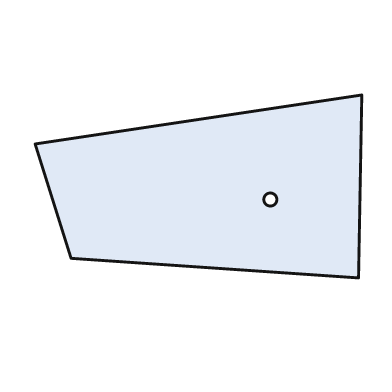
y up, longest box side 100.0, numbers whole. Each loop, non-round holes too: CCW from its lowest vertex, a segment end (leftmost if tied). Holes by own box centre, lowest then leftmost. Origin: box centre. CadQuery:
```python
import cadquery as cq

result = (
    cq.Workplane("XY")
    .moveTo(49.0, -28.0)
    .lineTo(50.0, 28.0)
    .lineTo(-50.0, 13.0)
    .lineTo(-39.0, -22.0)
    .close()
    .moveTo(22.0, -4.0)
    .circle(2.0)
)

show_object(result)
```